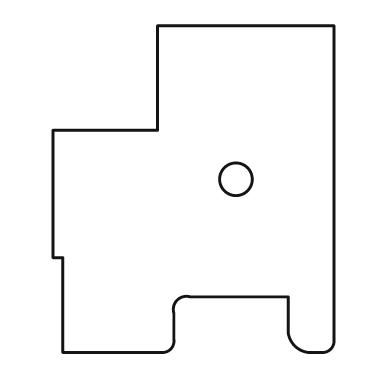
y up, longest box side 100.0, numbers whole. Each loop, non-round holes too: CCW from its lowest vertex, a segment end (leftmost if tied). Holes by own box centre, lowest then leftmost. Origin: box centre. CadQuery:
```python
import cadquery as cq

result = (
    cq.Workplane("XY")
    .moveTo(-40.0, -50.0)
    .lineTo(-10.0, -50.0)
    .threePointArc((-7.0, -49.0), (-6.0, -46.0))
    .lineTo(-6.0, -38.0)
    .threePointArc((-5.0, -34.0), (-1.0, -33.0))
    .lineTo(29.0, -33.0)
    .lineTo(29.0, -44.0)
    .threePointArc((31.0, -48.0), (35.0, -50.0))
    .lineTo(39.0, -50.0)
    .threePointArc((42.0, -49.0), (43.0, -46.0))
    .lineTo(43.0, 50.0)
    .lineTo(-11.0, 50.0)
    .lineTo(-11.0, 18.0)
    .lineTo(-43.0, 18.0)
    .lineTo(-43.0, -21.0)
    .lineTo(-40.0, -21.0)
    .close()
    .moveTo(13.0, 3.0)
    .circle(5.0)
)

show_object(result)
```